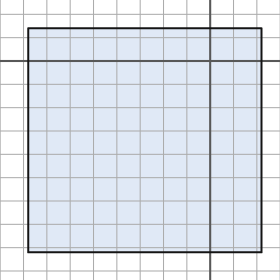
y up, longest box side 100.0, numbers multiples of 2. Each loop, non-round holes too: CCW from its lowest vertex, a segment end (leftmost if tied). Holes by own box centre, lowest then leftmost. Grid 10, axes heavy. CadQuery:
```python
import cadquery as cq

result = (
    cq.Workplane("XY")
    .moveTo(-78.0, -82.0)
    .lineTo(22.0, -82.0)
    .lineTo(22.0, 14.0)
    .lineTo(-78.0, 14.0)
    .close()
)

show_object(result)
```